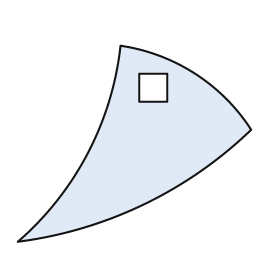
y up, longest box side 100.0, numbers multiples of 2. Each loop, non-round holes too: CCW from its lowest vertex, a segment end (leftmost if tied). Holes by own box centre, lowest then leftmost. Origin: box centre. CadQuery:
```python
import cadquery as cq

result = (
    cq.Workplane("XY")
    .moveTo(-50.0, -42.0)
    .threePointArc((4.0, -26.0), (50.0, 6.0))
    .threePointArc((26.0, 30.0), (-6.0, 42.0))
    .threePointArc((-20.0, -4.0), (-50.0, -42.0))
    .close()
    .moveTo(2.0, 18.0)
    .lineTo(14.0, 18.0)
    .lineTo(14.0, 30.0)
    .lineTo(2.0, 30.0)
    .close()
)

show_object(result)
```